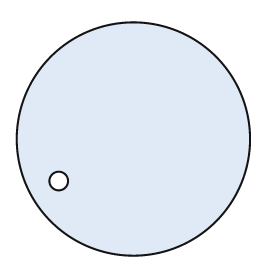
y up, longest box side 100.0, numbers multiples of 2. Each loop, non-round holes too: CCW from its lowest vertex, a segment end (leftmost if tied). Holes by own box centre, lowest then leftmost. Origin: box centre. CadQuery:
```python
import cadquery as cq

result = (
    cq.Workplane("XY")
    .moveTo(0.0, 0.0)
    .circle(50.0)
    .moveTo(-32.0, -18.0)
    .circle(4.0)
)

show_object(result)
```